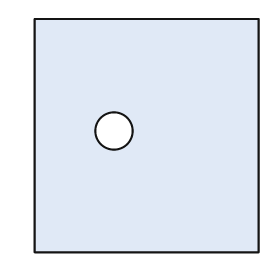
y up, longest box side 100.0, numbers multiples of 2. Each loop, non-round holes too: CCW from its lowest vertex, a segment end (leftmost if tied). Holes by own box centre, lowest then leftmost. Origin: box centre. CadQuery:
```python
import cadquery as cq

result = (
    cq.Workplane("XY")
    .moveTo(-48.0, -50.0)
    .lineTo(48.0, -50.0)
    .lineTo(48.0, 50.0)
    .lineTo(-48.0, 50.0)
    .close()
    .moveTo(-14.0, 2.0)
    .circle(8.0)
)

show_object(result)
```